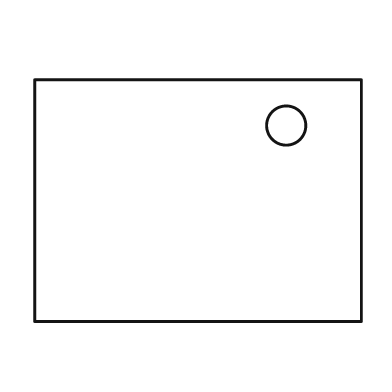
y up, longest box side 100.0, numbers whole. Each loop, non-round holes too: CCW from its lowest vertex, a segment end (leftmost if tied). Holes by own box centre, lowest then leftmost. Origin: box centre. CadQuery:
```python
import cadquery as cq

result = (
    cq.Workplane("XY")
    .moveTo(-50.0, -37.0)
    .lineTo(50.0, -37.0)
    .lineTo(50.0, 37.0)
    .lineTo(-50.0, 37.0)
    .close()
    .moveTo(27.0, 23.0)
    .circle(6.0)
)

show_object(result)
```